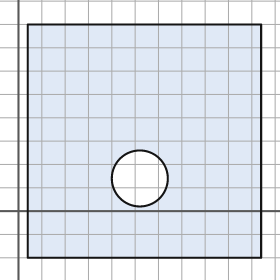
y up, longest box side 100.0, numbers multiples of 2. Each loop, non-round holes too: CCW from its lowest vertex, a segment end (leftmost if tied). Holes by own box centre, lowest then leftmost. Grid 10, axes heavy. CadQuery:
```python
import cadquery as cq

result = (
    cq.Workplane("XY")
    .moveTo(4.0, -20.0)
    .lineTo(104.0, -20.0)
    .lineTo(104.0, 80.0)
    .lineTo(4.0, 80.0)
    .close()
    .moveTo(52.0, 14.0)
    .circle(12.0)
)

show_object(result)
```